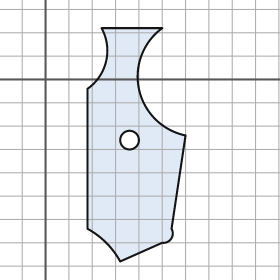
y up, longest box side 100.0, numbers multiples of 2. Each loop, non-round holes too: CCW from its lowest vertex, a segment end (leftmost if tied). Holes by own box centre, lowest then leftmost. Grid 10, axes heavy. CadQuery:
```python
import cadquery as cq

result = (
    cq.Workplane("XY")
    .moveTo(32.0, -78.0)
    .lineTo(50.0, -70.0)
    .threePointArc((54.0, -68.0), (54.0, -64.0))
    .lineTo(60.0, -24.0)
    .threePointArc((40.0, -4.0), (50.0, 22.0))
    .lineTo(24.0, 22.0)
    .threePointArc((26.0, 8.0), (18.0, -4.0))
    .lineTo(18.0, -64.0)
    .threePointArc((26.0, -70.0), (32.0, -78.0))
    .close()
    .moveTo(36.0, -26.0)
    .circle(4.0)
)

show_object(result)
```